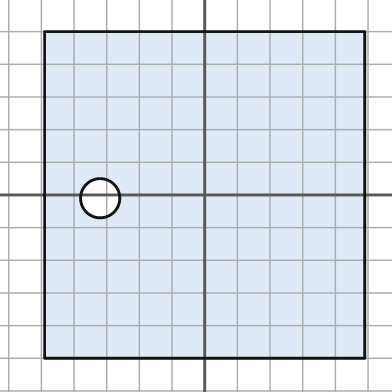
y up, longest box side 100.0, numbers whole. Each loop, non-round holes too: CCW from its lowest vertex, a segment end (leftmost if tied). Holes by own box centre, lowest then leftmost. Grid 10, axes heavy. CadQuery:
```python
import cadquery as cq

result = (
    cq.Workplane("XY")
    .moveTo(-49.0, -50.0)
    .lineTo(49.0, -50.0)
    .lineTo(49.0, 50.0)
    .lineTo(-49.0, 50.0)
    .close()
    .moveTo(-32.0, -1.0)
    .circle(6.0)
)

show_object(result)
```